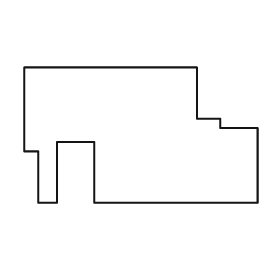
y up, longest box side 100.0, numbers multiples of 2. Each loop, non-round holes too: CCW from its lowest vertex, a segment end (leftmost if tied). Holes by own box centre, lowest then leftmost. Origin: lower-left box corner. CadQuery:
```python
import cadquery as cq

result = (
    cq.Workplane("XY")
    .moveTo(6.0, 0.0)
    .lineTo(14.0, 0.0)
    .lineTo(14.0, 26.0)
    .lineTo(30.0, 26.0)
    .lineTo(30.0, 0.0)
    .lineTo(100.0, 0.0)
    .lineTo(100.0, 32.0)
    .lineTo(84.0, 32.0)
    .lineTo(84.0, 36.0)
    .lineTo(74.0, 36.0)
    .lineTo(74.0, 58.0)
    .lineTo(0.0, 58.0)
    .lineTo(0.0, 22.0)
    .lineTo(6.0, 22.0)
    .close()
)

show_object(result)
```